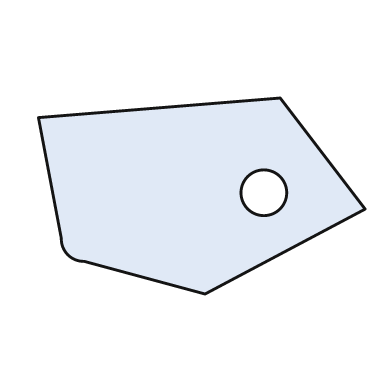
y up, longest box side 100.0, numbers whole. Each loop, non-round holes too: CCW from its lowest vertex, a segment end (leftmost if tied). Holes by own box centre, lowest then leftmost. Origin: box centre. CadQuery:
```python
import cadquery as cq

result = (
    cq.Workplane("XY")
    .moveTo(1.0, -30.0)
    .lineTo(50.0, -4.0)
    .lineTo(24.0, 30.0)
    .lineTo(-50.0, 24.0)
    .lineTo(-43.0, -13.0)
    .threePointArc((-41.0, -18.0), (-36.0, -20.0))
    .close()
    .moveTo(19.0, 1.0)
    .circle(7.0)
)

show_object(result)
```